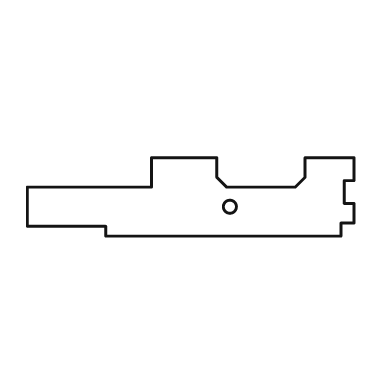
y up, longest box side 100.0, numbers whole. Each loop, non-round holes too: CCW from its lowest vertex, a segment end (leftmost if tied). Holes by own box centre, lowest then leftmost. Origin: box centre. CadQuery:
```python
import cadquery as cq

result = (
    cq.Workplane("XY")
    .moveTo(-26.0, -12.0)
    .lineTo(46.0, -12.0)
    .lineTo(46.0, -8.0)
    .lineTo(50.0, -8.0)
    .lineTo(50.0, -2.0)
    .lineTo(47.0, -2.0)
    .lineTo(47.0, 5.0)
    .lineTo(50.0, 5.0)
    .lineTo(50.0, 12.0)
    .lineTo(35.0, 12.0)
    .lineTo(35.0, 6.0)
    .lineTo(32.0, 3.0)
    .lineTo(11.0, 3.0)
    .lineTo(8.0, 6.0)
    .lineTo(8.0, 12.0)
    .lineTo(-12.0, 12.0)
    .lineTo(-12.0, 3.0)
    .lineTo(-50.0, 3.0)
    .lineTo(-50.0, -9.0)
    .lineTo(-26.0, -9.0)
    .close()
    .moveTo(12.0, -3.0)
    .circle(2.0)
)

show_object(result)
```